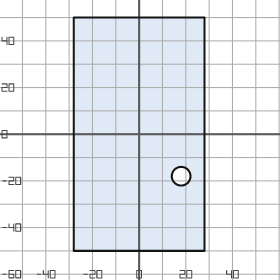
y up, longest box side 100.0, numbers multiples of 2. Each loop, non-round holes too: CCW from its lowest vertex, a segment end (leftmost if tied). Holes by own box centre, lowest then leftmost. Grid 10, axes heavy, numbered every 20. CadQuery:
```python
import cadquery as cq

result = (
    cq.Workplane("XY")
    .moveTo(-28.0, -50.0)
    .lineTo(28.0, -50.0)
    .lineTo(28.0, 50.0)
    .lineTo(-28.0, 50.0)
    .close()
    .moveTo(18.0, -18.0)
    .circle(4.0)
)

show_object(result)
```